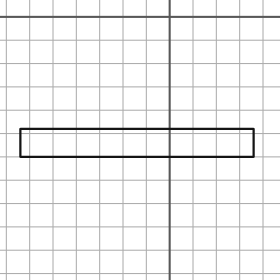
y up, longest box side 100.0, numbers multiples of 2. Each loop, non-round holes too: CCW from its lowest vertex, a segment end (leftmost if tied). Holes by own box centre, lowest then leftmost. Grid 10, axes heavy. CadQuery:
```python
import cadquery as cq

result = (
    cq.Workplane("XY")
    .moveTo(-64.0, -60.0)
    .lineTo(36.0, -60.0)
    .lineTo(36.0, -48.0)
    .lineTo(-64.0, -48.0)
    .close()
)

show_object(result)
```